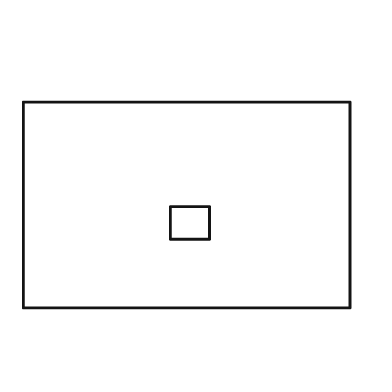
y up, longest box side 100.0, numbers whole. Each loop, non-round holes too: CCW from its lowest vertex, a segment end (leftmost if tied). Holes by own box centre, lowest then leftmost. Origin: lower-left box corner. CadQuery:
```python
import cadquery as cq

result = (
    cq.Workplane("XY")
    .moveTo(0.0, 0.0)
    .lineTo(100.0, 0.0)
    .lineTo(100.0, 63.0)
    .lineTo(0.0, 63.0)
    .close()
    .moveTo(45.0, 21.0)
    .lineTo(57.0, 21.0)
    .lineTo(57.0, 31.0)
    .lineTo(45.0, 31.0)
    .close()
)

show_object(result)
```